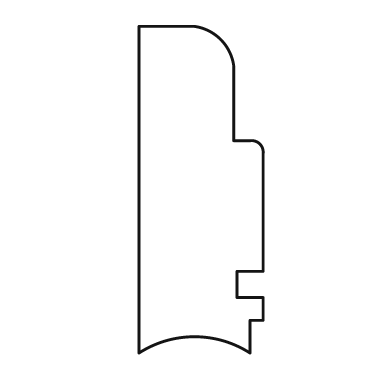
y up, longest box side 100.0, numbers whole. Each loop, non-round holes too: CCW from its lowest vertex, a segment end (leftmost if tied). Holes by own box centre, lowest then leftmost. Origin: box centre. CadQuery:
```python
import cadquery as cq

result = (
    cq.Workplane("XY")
    .moveTo(-19.0, -50.0)
    .threePointArc((-2.0, -45.0), (15.0, -50.0))
    .lineTo(15.0, -40.0)
    .lineTo(19.0, -40.0)
    .lineTo(19.0, -33.0)
    .lineTo(11.0, -33.0)
    .lineTo(11.0, -25.0)
    .lineTo(19.0, -25.0)
    .lineTo(19.0, 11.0)
    .threePointArc((18.0, 14.0), (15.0, 15.0))
    .lineTo(10.0, 15.0)
    .lineTo(10.0, 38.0)
    .threePointArc((6.0, 46.0), (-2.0, 50.0))
    .lineTo(-19.0, 50.0)
    .close()
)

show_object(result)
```